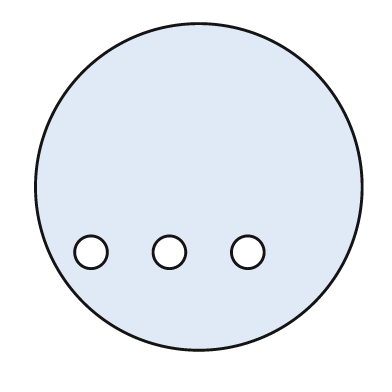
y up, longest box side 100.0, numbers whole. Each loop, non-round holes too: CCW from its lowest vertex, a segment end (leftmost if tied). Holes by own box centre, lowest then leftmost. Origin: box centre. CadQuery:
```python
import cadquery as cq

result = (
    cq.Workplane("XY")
    .moveTo(0.0, 0.0)
    .circle(50.0)
    .moveTo(-33.0, -20.0)
    .circle(5.0)
    .moveTo(-9.0, -20.0)
    .circle(5.0)
    .moveTo(15.0, -20.0)
    .circle(5.0)
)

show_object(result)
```